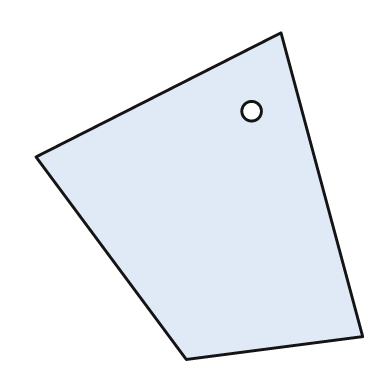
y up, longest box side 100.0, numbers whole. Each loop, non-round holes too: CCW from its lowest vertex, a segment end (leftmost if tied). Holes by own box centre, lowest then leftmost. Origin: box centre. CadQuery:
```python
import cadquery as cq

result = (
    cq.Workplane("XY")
    .moveTo(-4.0, -50.0)
    .lineTo(50.0, -43.0)
    .lineTo(25.0, 50.0)
    .lineTo(-50.0, 12.0)
    .close()
    .moveTo(16.0, 26.0)
    .circle(3.0)
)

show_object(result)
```